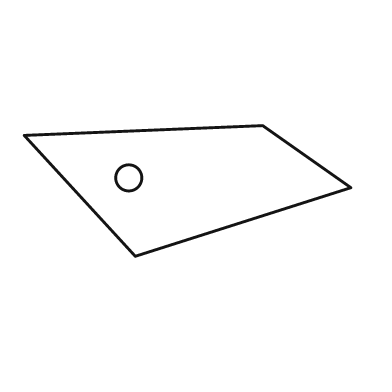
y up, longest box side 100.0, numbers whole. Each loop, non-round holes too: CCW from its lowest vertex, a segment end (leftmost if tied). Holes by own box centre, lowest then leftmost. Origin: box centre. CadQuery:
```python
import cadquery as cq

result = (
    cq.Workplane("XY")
    .moveTo(-16.0, -20.0)
    .lineTo(50.0, 1.0)
    .lineTo(23.0, 20.0)
    .lineTo(-50.0, 17.0)
    .close()
    .moveTo(-18.0, 4.0)
    .circle(4.0)
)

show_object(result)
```